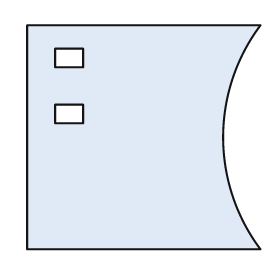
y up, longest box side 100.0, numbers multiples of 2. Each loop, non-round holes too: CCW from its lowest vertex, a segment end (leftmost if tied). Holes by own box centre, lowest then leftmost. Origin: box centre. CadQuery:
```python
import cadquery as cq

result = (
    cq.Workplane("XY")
    .moveTo(-50.0, -48.0)
    .lineTo(50.0, -48.0)
    .threePointArc((34.0, 0.0), (50.0, 48.0))
    .lineTo(-50.0, 48.0)
    .close()
    .moveTo(-38.0, 6.0)
    .lineTo(-26.0, 6.0)
    .lineTo(-26.0, 14.0)
    .lineTo(-38.0, 14.0)
    .close()
    .moveTo(-38.0, 30.0)
    .lineTo(-26.0, 30.0)
    .lineTo(-26.0, 38.0)
    .lineTo(-38.0, 38.0)
    .close()
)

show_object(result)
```